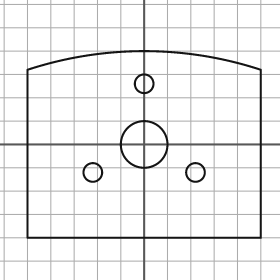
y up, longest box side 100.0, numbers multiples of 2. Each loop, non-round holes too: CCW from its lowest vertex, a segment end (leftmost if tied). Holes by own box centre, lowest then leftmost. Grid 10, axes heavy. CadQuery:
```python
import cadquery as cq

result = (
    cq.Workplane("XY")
    .moveTo(-50.0, -40.0)
    .lineTo(50.0, -40.0)
    .lineTo(50.0, 32.0)
    .threePointArc((0.0, 40.0), (-50.0, 32.0))
    .close()
    .moveTo(-22.0, -12.0)
    .circle(4.0)
    .moveTo(22.0, -12.0)
    .circle(4.0)
    .moveTo(0.0, 0.0)
    .circle(10.0)
    .moveTo(0.0, 26.0)
    .circle(4.0)
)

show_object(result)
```